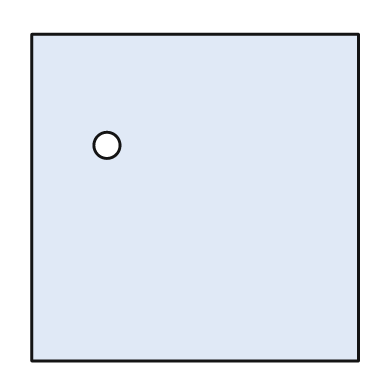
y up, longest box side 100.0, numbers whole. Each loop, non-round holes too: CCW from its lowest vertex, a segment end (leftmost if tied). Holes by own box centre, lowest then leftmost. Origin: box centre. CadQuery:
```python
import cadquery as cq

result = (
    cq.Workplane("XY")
    .moveTo(-50.0, -50.0)
    .lineTo(50.0, -50.0)
    .lineTo(50.0, 50.0)
    .lineTo(-50.0, 50.0)
    .close()
    .moveTo(-27.0, 16.0)
    .circle(4.0)
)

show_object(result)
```